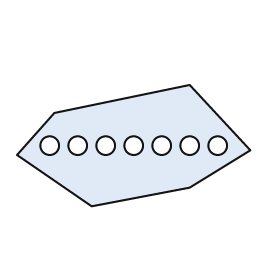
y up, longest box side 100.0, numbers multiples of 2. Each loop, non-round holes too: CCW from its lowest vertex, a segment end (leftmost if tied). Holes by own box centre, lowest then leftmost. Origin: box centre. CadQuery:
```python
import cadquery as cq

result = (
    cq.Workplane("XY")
    .moveTo(-18.0, -26.0)
    .lineTo(24.0, -18.0)
    .lineTo(50.0, -2.0)
    .lineTo(24.0, 26.0)
    .lineTo(-34.0, 14.0)
    .lineTo(-50.0, -4.0)
    .close()
    .moveTo(-36.0, 0.0)
    .circle(4.0)
    .moveTo(-24.0, 0.0)
    .circle(4.0)
    .moveTo(-12.0, 0.0)
    .circle(4.0)
    .moveTo(0.0, 0.0)
    .circle(4.0)
    .moveTo(12.0, 0.0)
    .circle(4.0)
    .moveTo(24.0, 0.0)
    .circle(4.0)
    .moveTo(36.0, 0.0)
    .circle(4.0)
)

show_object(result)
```